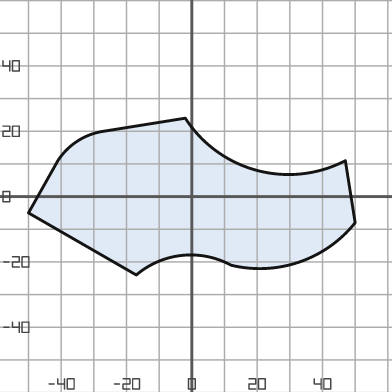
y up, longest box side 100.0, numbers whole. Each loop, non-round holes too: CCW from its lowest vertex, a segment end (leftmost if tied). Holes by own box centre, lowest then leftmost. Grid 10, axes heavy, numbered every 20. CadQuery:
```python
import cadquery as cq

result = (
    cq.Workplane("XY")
    .moveTo(-17.0, -24.0)
    .threePointArc((-3.0, -18.0), (12.0, -21.0))
    .threePointArc((33.0, -20.0), (50.0, -8.0))
    .lineTo(47.0, 11.0)
    .threePointArc((20.0, 8.0), (-2.0, 24.0))
    .lineTo(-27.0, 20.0)
    .threePointArc((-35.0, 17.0), (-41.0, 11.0))
    .lineTo(-50.0, -5.0)
    .close()
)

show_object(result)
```